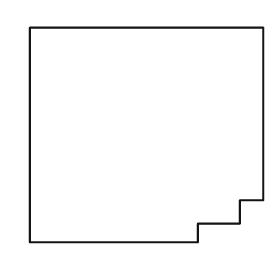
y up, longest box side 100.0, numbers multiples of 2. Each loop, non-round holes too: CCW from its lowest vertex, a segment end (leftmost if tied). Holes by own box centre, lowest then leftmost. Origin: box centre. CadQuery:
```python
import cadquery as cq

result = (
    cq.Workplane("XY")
    .moveTo(-50.0, -46.0)
    .lineTo(22.0, -46.0)
    .lineTo(22.0, -38.0)
    .lineTo(40.0, -38.0)
    .lineTo(40.0, -28.0)
    .lineTo(50.0, -28.0)
    .lineTo(50.0, 46.0)
    .lineTo(-50.0, 46.0)
    .close()
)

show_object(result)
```